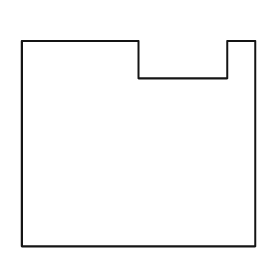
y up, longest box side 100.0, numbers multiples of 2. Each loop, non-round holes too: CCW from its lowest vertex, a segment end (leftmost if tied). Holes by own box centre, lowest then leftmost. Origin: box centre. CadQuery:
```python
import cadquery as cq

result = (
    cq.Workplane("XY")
    .moveTo(-50.0, -44.0)
    .lineTo(50.0, -44.0)
    .lineTo(50.0, 44.0)
    .lineTo(38.0, 44.0)
    .lineTo(38.0, 28.0)
    .lineTo(0.0, 28.0)
    .lineTo(0.0, 44.0)
    .lineTo(-50.0, 44.0)
    .close()
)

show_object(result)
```